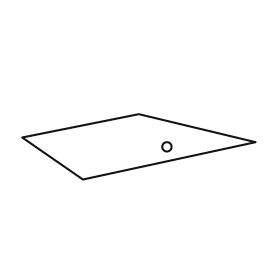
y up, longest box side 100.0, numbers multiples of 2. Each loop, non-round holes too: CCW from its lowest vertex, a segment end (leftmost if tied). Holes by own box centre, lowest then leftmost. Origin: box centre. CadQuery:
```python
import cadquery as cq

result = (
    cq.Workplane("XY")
    .moveTo(-24.0, -14.0)
    .lineTo(50.0, 2.0)
    .lineTo(0.0, 14.0)
    .lineTo(-50.0, 4.0)
    .close()
    .moveTo(12.0, 0.0)
    .circle(2.0)
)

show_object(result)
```